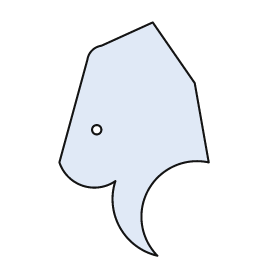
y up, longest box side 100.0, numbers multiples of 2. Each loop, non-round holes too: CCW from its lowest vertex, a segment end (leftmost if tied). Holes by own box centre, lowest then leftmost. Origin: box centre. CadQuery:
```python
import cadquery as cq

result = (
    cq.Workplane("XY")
    .moveTo(10.0, -50.0)
    .threePointArc((6.0, -22.0), (32.0, -10.0))
    .lineTo(26.0, 24.0)
    .lineTo(8.0, 50.0)
    .lineTo(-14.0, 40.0)
    .threePointArc((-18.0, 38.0), (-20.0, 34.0))
    .lineTo(-32.0, -10.0)
    .threePointArc((-22.0, -20.0), (-8.0, -18.0))
    .threePointArc((-6.0, -38.0), (10.0, -50.0))
    .close()
    .moveTo(-16.0, 4.0)
    .circle(2.0)
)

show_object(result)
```